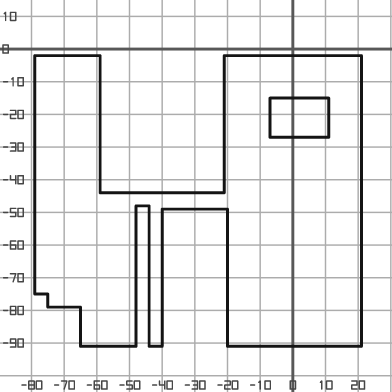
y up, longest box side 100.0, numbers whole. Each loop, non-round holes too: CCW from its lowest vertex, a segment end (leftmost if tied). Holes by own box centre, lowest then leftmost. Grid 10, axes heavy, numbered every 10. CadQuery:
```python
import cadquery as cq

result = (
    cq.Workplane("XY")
    .moveTo(-65.0, -91.0)
    .lineTo(-48.0, -91.0)
    .lineTo(-48.0, -48.0)
    .lineTo(-44.0, -48.0)
    .lineTo(-44.0, -91.0)
    .lineTo(-40.0, -91.0)
    .lineTo(-40.0, -49.0)
    .lineTo(-20.0, -49.0)
    .lineTo(-20.0, -91.0)
    .lineTo(21.0, -91.0)
    .lineTo(21.0, -2.0)
    .lineTo(-21.0, -2.0)
    .lineTo(-21.0, -44.0)
    .lineTo(-59.0, -44.0)
    .lineTo(-59.0, -2.0)
    .lineTo(-79.0, -2.0)
    .lineTo(-79.0, -75.0)
    .lineTo(-75.0, -75.0)
    .lineTo(-75.0, -79.0)
    .lineTo(-65.0, -79.0)
    .close()
    .moveTo(-7.0, -27.0)
    .lineTo(11.0, -27.0)
    .lineTo(11.0, -15.0)
    .lineTo(-7.0, -15.0)
    .close()
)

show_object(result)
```